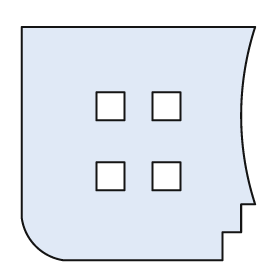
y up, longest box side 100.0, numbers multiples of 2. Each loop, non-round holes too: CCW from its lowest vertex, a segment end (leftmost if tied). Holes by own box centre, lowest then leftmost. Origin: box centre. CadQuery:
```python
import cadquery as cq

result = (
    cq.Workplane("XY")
    .moveTo(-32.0, -50.0)
    .lineTo(36.0, -50.0)
    .lineTo(36.0, -38.0)
    .lineTo(44.0, -38.0)
    .lineTo(44.0, -26.0)
    .lineTo(50.0, -26.0)
    .threePointArc((44.0, 12.0), (50.0, 50.0))
    .lineTo(-50.0, 50.0)
    .lineTo(-50.0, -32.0)
    .threePointArc((-44.0, -44.0), (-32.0, -50.0))
    .close()
    .moveTo(-18.0, -20.0)
    .lineTo(-6.0, -20.0)
    .lineTo(-6.0, -8.0)
    .lineTo(-18.0, -8.0)
    .close()
    .moveTo(6.0, -20.0)
    .lineTo(18.0, -20.0)
    .lineTo(18.0, -8.0)
    .lineTo(6.0, -8.0)
    .close()
    .moveTo(-18.0, 10.0)
    .lineTo(-6.0, 10.0)
    .lineTo(-6.0, 22.0)
    .lineTo(-18.0, 22.0)
    .close()
    .moveTo(6.0, 10.0)
    .lineTo(18.0, 10.0)
    .lineTo(18.0, 22.0)
    .lineTo(6.0, 22.0)
    .close()
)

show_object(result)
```